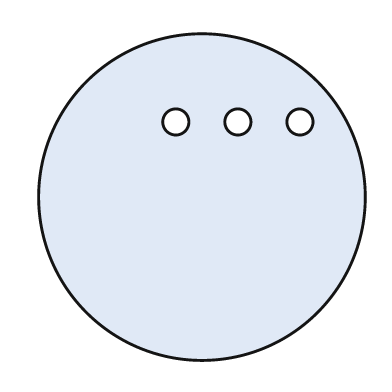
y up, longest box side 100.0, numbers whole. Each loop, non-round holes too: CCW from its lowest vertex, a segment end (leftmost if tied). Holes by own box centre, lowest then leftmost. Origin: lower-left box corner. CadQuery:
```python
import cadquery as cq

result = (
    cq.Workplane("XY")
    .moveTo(50.0, 50.0)
    .circle(50.0)
    .moveTo(42.0, 73.0)
    .circle(4.0)
    .moveTo(61.0, 73.0)
    .circle(4.0)
    .moveTo(80.0, 73.0)
    .circle(4.0)
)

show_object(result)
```